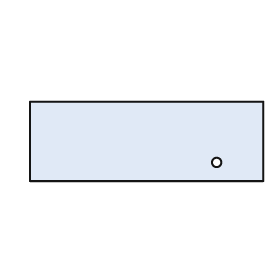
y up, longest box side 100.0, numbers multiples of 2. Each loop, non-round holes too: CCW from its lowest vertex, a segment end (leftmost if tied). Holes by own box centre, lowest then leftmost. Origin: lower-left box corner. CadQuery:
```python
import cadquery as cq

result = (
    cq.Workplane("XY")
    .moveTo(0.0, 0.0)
    .lineTo(100.0, 0.0)
    .lineTo(100.0, 34.0)
    .lineTo(0.0, 34.0)
    .close()
    .moveTo(80.0, 8.0)
    .circle(2.0)
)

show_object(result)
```